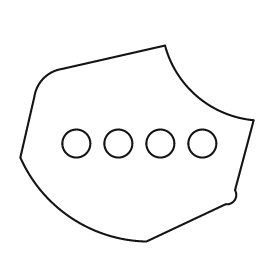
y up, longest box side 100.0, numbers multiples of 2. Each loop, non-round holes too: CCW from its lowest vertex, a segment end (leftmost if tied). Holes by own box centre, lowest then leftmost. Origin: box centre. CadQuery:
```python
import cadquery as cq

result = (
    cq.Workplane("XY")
    .moveTo(4.0, -42.0)
    .lineTo(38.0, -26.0)
    .threePointArc((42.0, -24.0), (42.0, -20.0))
    .lineTo(50.0, 10.0)
    .threePointArc((26.0, 20.0), (12.0, 42.0))
    .lineTo(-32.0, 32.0)
    .threePointArc((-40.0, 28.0), (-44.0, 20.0))
    .lineTo(-50.0, -6.0)
    .threePointArc((-28.0, -32.0), (4.0, -42.0))
    .close()
    .moveTo(-26.0, 0.0)
    .circle(6.0)
    .moveTo(-8.0, 0.0)
    .circle(6.0)
    .moveTo(10.0, 0.0)
    .circle(6.0)
    .moveTo(28.0, 0.0)
    .circle(6.0)
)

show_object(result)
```